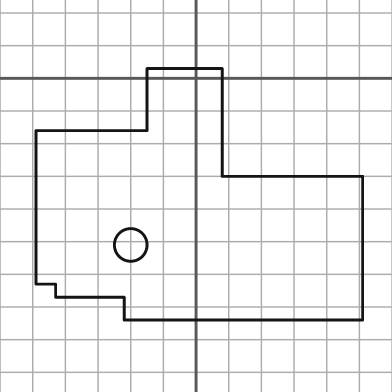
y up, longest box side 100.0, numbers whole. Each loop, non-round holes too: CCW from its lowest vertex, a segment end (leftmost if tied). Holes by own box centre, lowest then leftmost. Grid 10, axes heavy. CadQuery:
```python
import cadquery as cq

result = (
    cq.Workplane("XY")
    .moveTo(-22.0, -74.0)
    .lineTo(51.0, -74.0)
    .lineTo(51.0, -30.0)
    .lineTo(8.0, -30.0)
    .lineTo(8.0, 3.0)
    .lineTo(-15.0, 3.0)
    .lineTo(-15.0, -16.0)
    .lineTo(-49.0, -16.0)
    .lineTo(-49.0, -63.0)
    .lineTo(-43.0, -63.0)
    .lineTo(-43.0, -67.0)
    .lineTo(-22.0, -67.0)
    .close()
    .moveTo(-20.0, -51.0)
    .circle(5.0)
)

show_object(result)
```